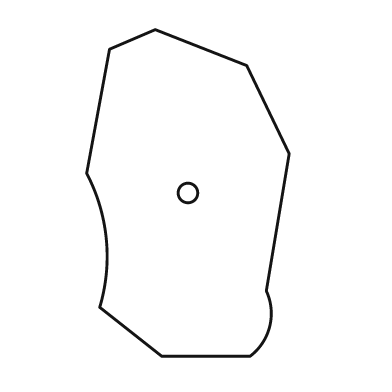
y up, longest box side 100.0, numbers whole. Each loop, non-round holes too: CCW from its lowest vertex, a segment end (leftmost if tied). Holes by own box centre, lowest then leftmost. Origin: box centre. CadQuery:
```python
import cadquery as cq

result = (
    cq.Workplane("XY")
    .moveTo(-8.0, -50.0)
    .lineTo(19.0, -50.0)
    .threePointArc((25.0, -41.0), (24.0, -30.0))
    .lineTo(31.0, 12.0)
    .lineTo(18.0, 39.0)
    .lineTo(-10.0, 50.0)
    .lineTo(-24.0, 44.0)
    .lineTo(-31.0, 6.0)
    .threePointArc((-25.0, -14.0), (-27.0, -35.0))
    .close()
    .moveTo(0.0, 0.0)
    .circle(3.0)
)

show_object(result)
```